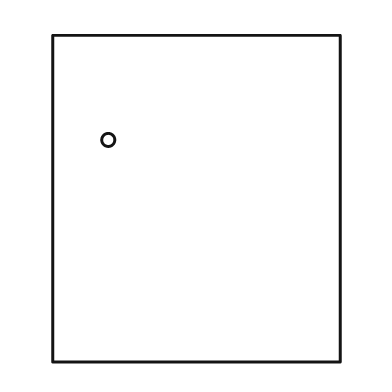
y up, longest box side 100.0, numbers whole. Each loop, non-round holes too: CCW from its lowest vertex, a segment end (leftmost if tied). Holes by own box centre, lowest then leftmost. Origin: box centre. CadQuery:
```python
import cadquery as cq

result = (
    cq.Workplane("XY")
    .moveTo(-44.0, -50.0)
    .lineTo(44.0, -50.0)
    .lineTo(44.0, 50.0)
    .lineTo(-44.0, 50.0)
    .close()
    .moveTo(-27.0, 18.0)
    .circle(2.0)
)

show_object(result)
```